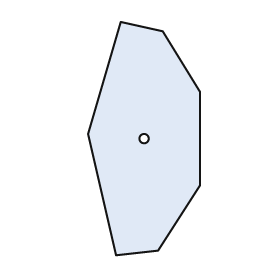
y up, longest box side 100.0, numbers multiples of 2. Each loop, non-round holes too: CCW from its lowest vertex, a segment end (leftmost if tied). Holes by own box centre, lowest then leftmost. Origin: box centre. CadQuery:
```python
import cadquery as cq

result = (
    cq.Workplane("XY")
    .moveTo(-12.0, -50.0)
    .lineTo(6.0, -48.0)
    .lineTo(24.0, -20.0)
    .lineTo(24.0, 20.0)
    .lineTo(8.0, 46.0)
    .lineTo(-10.0, 50.0)
    .lineTo(-24.0, 2.0)
    .close()
    .moveTo(0.0, 0.0)
    .circle(2.0)
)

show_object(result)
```